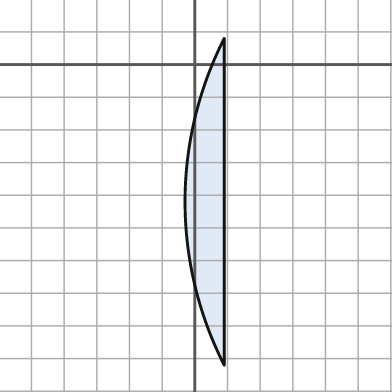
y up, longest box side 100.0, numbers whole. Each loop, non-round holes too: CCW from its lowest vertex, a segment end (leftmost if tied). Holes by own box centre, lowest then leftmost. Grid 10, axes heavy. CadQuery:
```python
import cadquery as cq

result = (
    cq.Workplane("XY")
    .moveTo(9.0, -92.0)
    .lineTo(9.0, 8.0)
    .threePointArc((-3.0, -42.0), (9.0, -92.0))
    .close()
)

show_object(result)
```